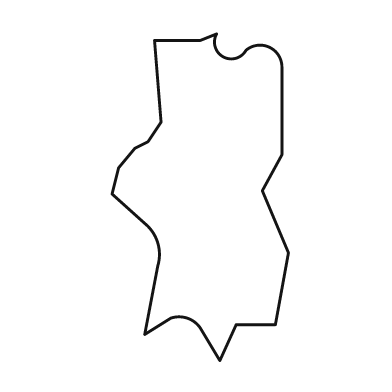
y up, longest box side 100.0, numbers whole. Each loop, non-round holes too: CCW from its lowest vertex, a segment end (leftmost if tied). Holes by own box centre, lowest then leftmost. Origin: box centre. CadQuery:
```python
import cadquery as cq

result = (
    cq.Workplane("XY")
    .moveTo(6.0, -50.0)
    .lineTo(11.0, -39.0)
    .lineTo(23.0, -39.0)
    .lineTo(27.0, -17.0)
    .lineTo(19.0, 2.0)
    .lineTo(25.0, 13.0)
    .lineTo(25.0, 40.0)
    .threePointArc((21.0, 46.0), (14.0, 45.0))
    .threePointArc((7.0, 43.0), (5.0, 50.0))
    .lineTo(0.0, 48.0)
    .lineTo(-14.0, 48.0)
    .lineTo(-12.0, 23.0)
    .lineTo(-16.0, 17.0)
    .lineTo(-20.0, 15.0)
    .lineTo(-25.0, 9.0)
    .lineTo(-27.0, 1.0)
    .lineTo(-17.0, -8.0)
    .threePointArc((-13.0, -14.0), (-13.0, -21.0))
    .lineTo(-17.0, -42.0)
    .lineTo(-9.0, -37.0)
    .threePointArc((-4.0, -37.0), (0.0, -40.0))
    .close()
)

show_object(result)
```